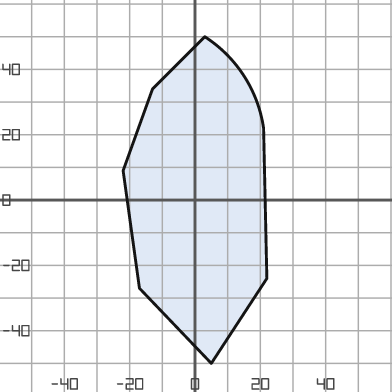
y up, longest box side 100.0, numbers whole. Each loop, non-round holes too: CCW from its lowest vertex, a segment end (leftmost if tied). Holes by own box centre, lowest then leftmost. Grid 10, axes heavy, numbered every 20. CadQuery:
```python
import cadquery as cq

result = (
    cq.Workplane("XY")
    .moveTo(5.0, -50.0)
    .lineTo(22.0, -24.0)
    .lineTo(21.0, 22.0)
    .threePointArc((15.0, 38.0), (3.0, 50.0))
    .lineTo(-13.0, 34.0)
    .lineTo(-22.0, 9.0)
    .lineTo(-17.0, -27.0)
    .close()
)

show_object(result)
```